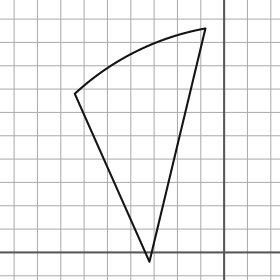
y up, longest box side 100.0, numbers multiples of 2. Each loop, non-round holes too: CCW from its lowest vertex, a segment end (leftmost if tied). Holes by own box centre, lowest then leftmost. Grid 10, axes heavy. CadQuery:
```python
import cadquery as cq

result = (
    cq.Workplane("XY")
    .moveTo(-32.0, -4.0)
    .lineTo(-8.0, 96.0)
    .threePointArc((-38.0, 86.0), (-64.0, 68.0))
    .close()
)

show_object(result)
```